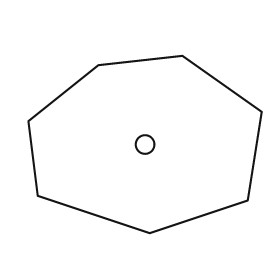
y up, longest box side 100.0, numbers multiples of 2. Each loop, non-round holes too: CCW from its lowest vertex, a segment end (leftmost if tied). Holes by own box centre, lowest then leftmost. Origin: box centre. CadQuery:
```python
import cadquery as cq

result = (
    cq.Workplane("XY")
    .moveTo(2.0, -38.0)
    .lineTo(44.0, -24.0)
    .lineTo(50.0, 14.0)
    .lineTo(16.0, 38.0)
    .lineTo(-20.0, 34.0)
    .lineTo(-50.0, 10.0)
    .lineTo(-46.0, -22.0)
    .close()
    .moveTo(0.0, 0.0)
    .circle(4.0)
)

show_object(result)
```